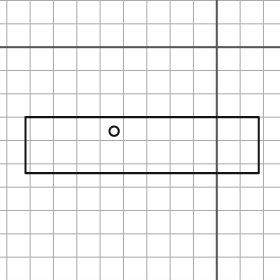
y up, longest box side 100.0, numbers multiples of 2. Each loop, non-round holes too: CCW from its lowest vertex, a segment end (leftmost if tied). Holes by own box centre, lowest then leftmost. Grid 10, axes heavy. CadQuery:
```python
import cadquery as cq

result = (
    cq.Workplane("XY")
    .moveTo(-82.0, -54.0)
    .lineTo(18.0, -54.0)
    .lineTo(18.0, -30.0)
    .lineTo(-82.0, -30.0)
    .close()
    .moveTo(-44.0, -36.0)
    .circle(2.0)
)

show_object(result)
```